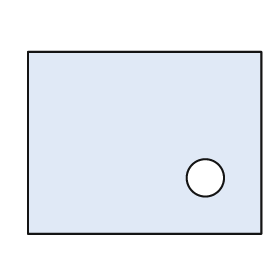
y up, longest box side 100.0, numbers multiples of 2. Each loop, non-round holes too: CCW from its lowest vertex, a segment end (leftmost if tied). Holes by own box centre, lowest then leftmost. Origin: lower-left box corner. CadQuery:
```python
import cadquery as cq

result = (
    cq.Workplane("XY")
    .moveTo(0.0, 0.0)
    .lineTo(100.0, 0.0)
    .lineTo(100.0, 78.0)
    .lineTo(0.0, 78.0)
    .close()
    .moveTo(76.0, 24.0)
    .circle(8.0)
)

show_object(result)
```